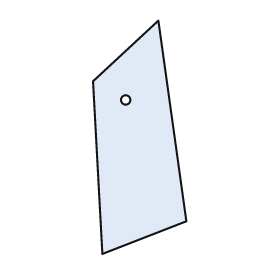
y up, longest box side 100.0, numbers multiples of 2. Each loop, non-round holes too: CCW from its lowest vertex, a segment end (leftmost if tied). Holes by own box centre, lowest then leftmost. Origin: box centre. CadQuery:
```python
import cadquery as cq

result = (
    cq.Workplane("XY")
    .moveTo(-16.0, -50.0)
    .lineTo(20.0, -36.0)
    .lineTo(8.0, 50.0)
    .lineTo(-20.0, 24.0)
    .close()
    .moveTo(-6.0, 16.0)
    .circle(2.0)
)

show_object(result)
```